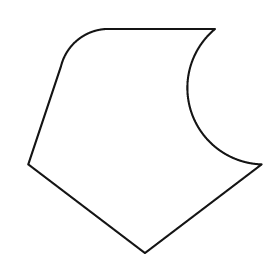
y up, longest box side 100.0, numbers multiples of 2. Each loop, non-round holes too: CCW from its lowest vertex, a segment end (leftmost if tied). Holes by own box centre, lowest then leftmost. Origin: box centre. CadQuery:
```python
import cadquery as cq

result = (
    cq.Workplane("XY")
    .moveTo(0.0, -48.0)
    .lineTo(50.0, -10.0)
    .threePointArc((20.0, 12.0), (30.0, 48.0))
    .lineTo(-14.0, 48.0)
    .threePointArc((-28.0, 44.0), (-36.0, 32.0))
    .lineTo(-50.0, -10.0)
    .close()
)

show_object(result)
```